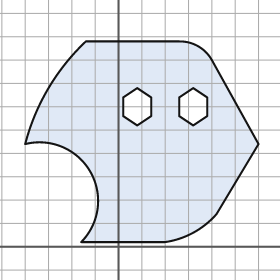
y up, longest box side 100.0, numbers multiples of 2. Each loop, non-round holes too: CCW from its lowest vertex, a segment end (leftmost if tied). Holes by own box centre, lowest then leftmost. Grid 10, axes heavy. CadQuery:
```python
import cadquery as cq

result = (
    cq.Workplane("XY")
    .moveTo(-16.0, 2.0)
    .lineTo(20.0, 2.0)
    .threePointArc((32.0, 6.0), (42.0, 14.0))
    .lineTo(60.0, 44.0)
    .lineTo(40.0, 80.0)
    .threePointArc((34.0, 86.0), (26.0, 88.0))
    .lineTo(-14.0, 88.0)
    .threePointArc((-30.0, 68.0), (-40.0, 44.0))
    .threePointArc((-12.0, 32.0), (-16.0, 2.0))
    .close()
    .moveTo(8.0, 52.0)
    .lineTo(14.0, 56.0)
    .lineTo(14.0, 64.0)
    .lineTo(8.0, 68.0)
    .lineTo(2.0, 64.0)
    .lineTo(2.0, 56.0)
    .close()
    .moveTo(32.0, 52.0)
    .lineTo(38.0, 56.0)
    .lineTo(38.0, 64.0)
    .lineTo(32.0, 68.0)
    .lineTo(26.0, 64.0)
    .lineTo(26.0, 56.0)
    .close()
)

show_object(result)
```